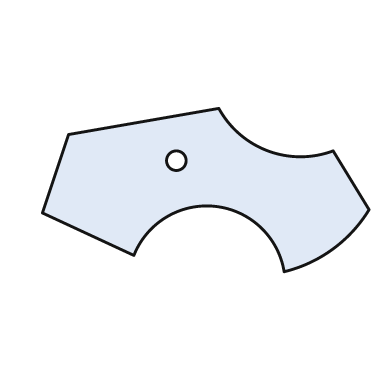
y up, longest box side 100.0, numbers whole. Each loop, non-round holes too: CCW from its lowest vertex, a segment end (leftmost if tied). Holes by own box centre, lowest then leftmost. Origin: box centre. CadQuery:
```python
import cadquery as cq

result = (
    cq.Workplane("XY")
    .moveTo(24.0, -25.0)
    .threePointArc((39.0, -18.0), (50.0, -6.0))
    .lineTo(39.0, 12.0)
    .threePointArc((19.0, 12.0), (4.0, 25.0))
    .lineTo(-42.0, 17.0)
    .lineTo(-50.0, -7.0)
    .lineTo(-22.0, -20.0)
    .threePointArc((3.0, -5.0), (24.0, -25.0))
    .close()
    .moveTo(-9.0, 9.0)
    .circle(3.0)
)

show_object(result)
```